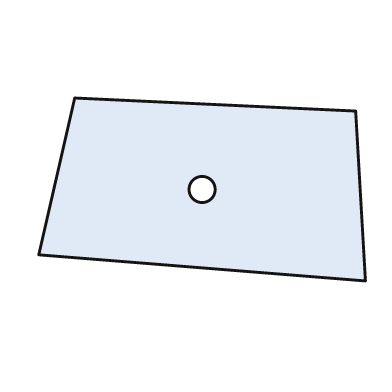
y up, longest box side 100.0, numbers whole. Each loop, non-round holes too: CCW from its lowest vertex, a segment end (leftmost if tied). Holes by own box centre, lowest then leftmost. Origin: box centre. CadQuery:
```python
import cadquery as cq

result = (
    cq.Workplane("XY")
    .moveTo(50.0, -28.0)
    .lineTo(47.0, 24.0)
    .lineTo(-39.0, 28.0)
    .lineTo(-50.0, -20.0)
    .close()
    .moveTo(0.0, 0.0)
    .circle(4.0)
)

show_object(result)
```